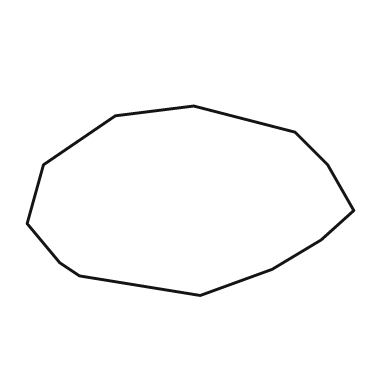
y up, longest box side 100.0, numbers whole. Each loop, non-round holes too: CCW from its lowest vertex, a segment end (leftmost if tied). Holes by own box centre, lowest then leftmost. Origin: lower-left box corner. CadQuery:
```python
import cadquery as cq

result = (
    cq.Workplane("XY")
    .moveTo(53.0, 0.0)
    .lineTo(75.0, 8.0)
    .lineTo(90.0, 17.0)
    .lineTo(100.0, 26.0)
    .lineTo(92.0, 40.0)
    .lineTo(82.0, 50.0)
    .lineTo(51.0, 58.0)
    .lineTo(27.0, 55.0)
    .lineTo(5.0, 40.0)
    .lineTo(0.0, 22.0)
    .lineTo(10.0, 10.0)
    .lineTo(16.0, 6.0)
    .close()
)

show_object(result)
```